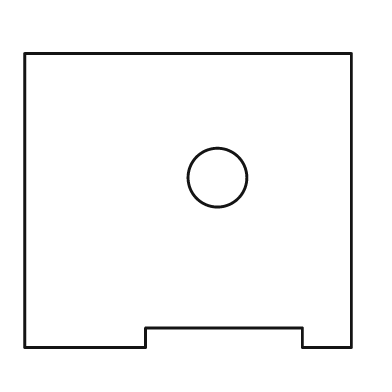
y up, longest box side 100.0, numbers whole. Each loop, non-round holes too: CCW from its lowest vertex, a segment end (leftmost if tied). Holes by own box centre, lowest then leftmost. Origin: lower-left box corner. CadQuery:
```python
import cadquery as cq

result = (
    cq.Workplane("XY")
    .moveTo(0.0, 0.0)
    .lineTo(37.0, 0.0)
    .lineTo(37.0, 6.0)
    .lineTo(85.0, 6.0)
    .lineTo(85.0, 0.0)
    .lineTo(100.0, 0.0)
    .lineTo(100.0, 90.0)
    .lineTo(0.0, 90.0)
    .close()
    .moveTo(59.0, 52.0)
    .circle(9.0)
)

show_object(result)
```